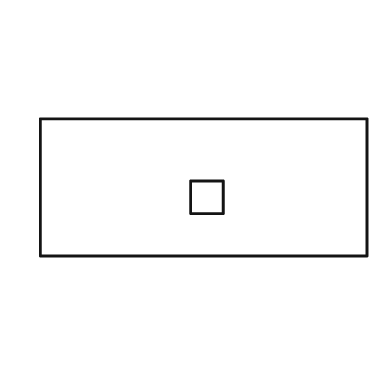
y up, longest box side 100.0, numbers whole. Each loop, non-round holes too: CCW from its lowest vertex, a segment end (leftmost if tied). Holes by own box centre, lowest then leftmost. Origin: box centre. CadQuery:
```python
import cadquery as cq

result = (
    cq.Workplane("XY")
    .moveTo(-50.0, -21.0)
    .lineTo(50.0, -21.0)
    .lineTo(50.0, 21.0)
    .lineTo(-50.0, 21.0)
    .close()
    .moveTo(-4.0, -8.0)
    .lineTo(6.0, -8.0)
    .lineTo(6.0, 2.0)
    .lineTo(-4.0, 2.0)
    .close()
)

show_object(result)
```